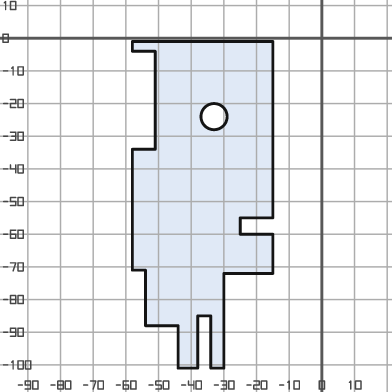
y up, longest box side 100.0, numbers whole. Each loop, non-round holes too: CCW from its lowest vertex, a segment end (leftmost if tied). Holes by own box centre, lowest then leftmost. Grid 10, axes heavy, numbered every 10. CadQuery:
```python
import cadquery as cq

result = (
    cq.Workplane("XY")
    .moveTo(-44.0, -101.0)
    .lineTo(-38.0, -101.0)
    .lineTo(-38.0, -85.0)
    .lineTo(-34.0, -85.0)
    .lineTo(-34.0, -101.0)
    .lineTo(-30.0, -101.0)
    .lineTo(-30.0, -72.0)
    .lineTo(-15.0, -72.0)
    .lineTo(-15.0, -60.0)
    .lineTo(-25.0, -60.0)
    .lineTo(-25.0, -55.0)
    .lineTo(-15.0, -55.0)
    .lineTo(-15.0, -1.0)
    .lineTo(-58.0, -1.0)
    .lineTo(-58.0, -4.0)
    .lineTo(-51.0, -4.0)
    .lineTo(-51.0, -34.0)
    .lineTo(-58.0, -34.0)
    .lineTo(-58.0, -71.0)
    .lineTo(-54.0, -71.0)
    .lineTo(-54.0, -88.0)
    .lineTo(-44.0, -88.0)
    .close()
    .moveTo(-33.0, -24.0)
    .circle(4.0)
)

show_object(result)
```